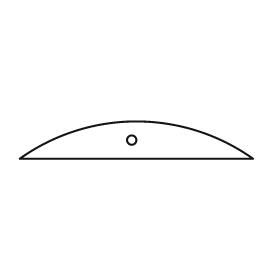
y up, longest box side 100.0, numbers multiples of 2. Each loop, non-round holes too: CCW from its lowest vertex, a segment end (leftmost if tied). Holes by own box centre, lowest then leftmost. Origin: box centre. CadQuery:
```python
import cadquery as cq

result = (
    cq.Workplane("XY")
    .moveTo(-50.0, -8.0)
    .lineTo(50.0, -8.0)
    .threePointArc((0.0, 8.0), (-50.0, -8.0))
    .close()
    .moveTo(-2.0, 0.0)
    .circle(2.0)
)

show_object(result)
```